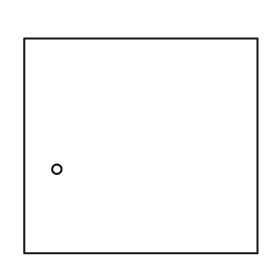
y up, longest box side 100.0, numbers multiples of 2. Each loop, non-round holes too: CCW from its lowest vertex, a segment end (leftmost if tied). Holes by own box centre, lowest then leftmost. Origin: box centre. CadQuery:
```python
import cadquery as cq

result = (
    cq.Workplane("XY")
    .moveTo(-50.0, -46.0)
    .lineTo(50.0, -46.0)
    .lineTo(50.0, 46.0)
    .lineTo(-50.0, 46.0)
    .close()
    .moveTo(-36.0, -10.0)
    .circle(2.0)
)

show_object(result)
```